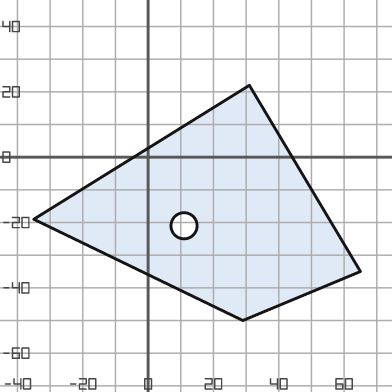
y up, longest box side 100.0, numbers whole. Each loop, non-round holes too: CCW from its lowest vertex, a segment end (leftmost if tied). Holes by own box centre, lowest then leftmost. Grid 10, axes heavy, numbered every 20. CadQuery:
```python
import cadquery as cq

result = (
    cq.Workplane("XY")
    .moveTo(29.0, -50.0)
    .lineTo(65.0, -35.0)
    .lineTo(31.0, 22.0)
    .lineTo(-35.0, -19.0)
    .close()
    .moveTo(11.0, -21.0)
    .circle(4.0)
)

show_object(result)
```